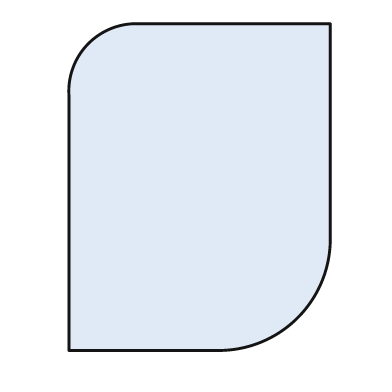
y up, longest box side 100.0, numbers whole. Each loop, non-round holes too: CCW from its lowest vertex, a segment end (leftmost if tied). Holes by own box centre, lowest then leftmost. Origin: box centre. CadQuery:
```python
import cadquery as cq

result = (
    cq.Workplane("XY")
    .moveTo(-40.0, -50.0)
    .lineTo(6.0, -50.0)
    .threePointArc((30.0, -40.0), (40.0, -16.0))
    .lineTo(40.0, 50.0)
    .lineTo(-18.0, 50.0)
    .threePointArc((-34.0, 44.0), (-40.0, 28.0))
    .close()
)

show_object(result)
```